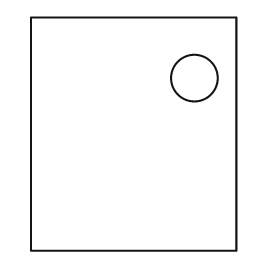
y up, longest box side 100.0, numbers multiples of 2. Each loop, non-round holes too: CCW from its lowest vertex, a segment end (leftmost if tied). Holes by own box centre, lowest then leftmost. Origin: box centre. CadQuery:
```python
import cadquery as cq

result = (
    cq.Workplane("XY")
    .moveTo(-44.0, -50.0)
    .lineTo(44.0, -50.0)
    .lineTo(44.0, 50.0)
    .lineTo(-44.0, 50.0)
    .close()
    .moveTo(26.0, 24.0)
    .circle(10.0)
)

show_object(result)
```